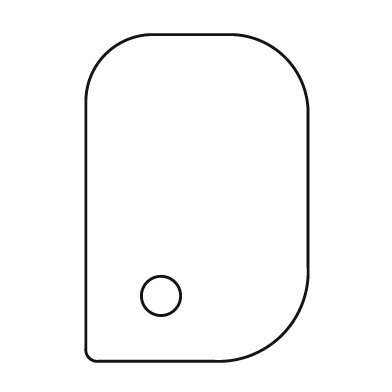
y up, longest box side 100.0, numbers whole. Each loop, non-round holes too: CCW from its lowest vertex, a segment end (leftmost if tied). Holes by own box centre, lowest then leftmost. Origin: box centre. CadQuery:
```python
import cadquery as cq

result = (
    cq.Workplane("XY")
    .moveTo(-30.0, -50.0)
    .lineTo(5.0, -50.0)
    .threePointArc((26.0, -42.0), (34.0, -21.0))
    .lineTo(34.0, 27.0)
    .threePointArc((27.0, 43.0), (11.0, 50.0))
    .lineTo(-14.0, 50.0)
    .threePointArc((-28.0, 44.0), (-34.0, 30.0))
    .lineTo(-34.0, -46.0)
    .threePointArc((-33.0, -49.0), (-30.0, -50.0))
    .close()
    .moveTo(-11.0, -30.0)
    .circle(6.0)
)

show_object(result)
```